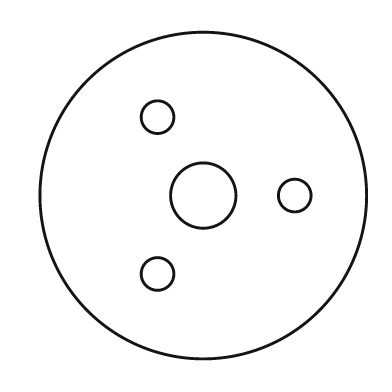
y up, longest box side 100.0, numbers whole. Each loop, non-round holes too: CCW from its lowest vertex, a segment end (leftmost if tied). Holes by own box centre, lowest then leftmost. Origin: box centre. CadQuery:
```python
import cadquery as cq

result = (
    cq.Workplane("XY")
    .moveTo(0.0, 0.0)
    .circle(50.0)
    .moveTo(-14.0, -24.0)
    .circle(5.0)
    .moveTo(0.0, 0.0)
    .circle(10.0)
    .moveTo(28.0, 0.0)
    .circle(5.0)
    .moveTo(-14.0, 24.0)
    .circle(5.0)
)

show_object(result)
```